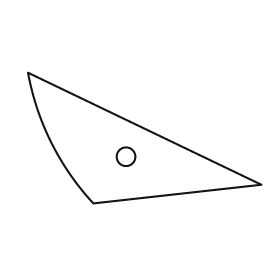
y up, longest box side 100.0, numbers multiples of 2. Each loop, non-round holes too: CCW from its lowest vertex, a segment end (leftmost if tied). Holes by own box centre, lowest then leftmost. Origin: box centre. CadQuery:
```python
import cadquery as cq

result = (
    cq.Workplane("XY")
    .moveTo(-22.0, -28.0)
    .lineTo(50.0, -20.0)
    .lineTo(-50.0, 28.0)
    .threePointArc((-40.0, -2.0), (-22.0, -28.0))
    .close()
    .moveTo(-8.0, -8.0)
    .circle(4.0)
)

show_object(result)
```